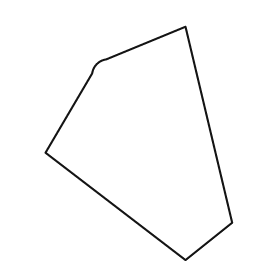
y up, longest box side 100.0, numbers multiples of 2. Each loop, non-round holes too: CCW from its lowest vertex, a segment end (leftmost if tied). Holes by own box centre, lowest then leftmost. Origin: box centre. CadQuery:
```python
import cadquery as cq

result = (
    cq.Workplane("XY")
    .moveTo(20.0, -50.0)
    .lineTo(40.0, -34.0)
    .lineTo(20.0, 50.0)
    .lineTo(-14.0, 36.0)
    .threePointArc((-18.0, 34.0), (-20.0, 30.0))
    .lineTo(-40.0, -4.0)
    .close()
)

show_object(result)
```